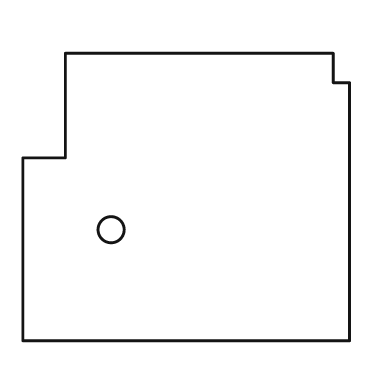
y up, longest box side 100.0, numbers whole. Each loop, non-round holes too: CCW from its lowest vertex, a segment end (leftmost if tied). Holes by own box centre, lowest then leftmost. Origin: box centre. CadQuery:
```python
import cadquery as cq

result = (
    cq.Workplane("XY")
    .moveTo(-50.0, -44.0)
    .lineTo(50.0, -44.0)
    .lineTo(50.0, 35.0)
    .lineTo(45.0, 35.0)
    .lineTo(45.0, 44.0)
    .lineTo(-37.0, 44.0)
    .lineTo(-37.0, 12.0)
    .lineTo(-50.0, 12.0)
    .close()
    .moveTo(-23.0, -10.0)
    .circle(4.0)
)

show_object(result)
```